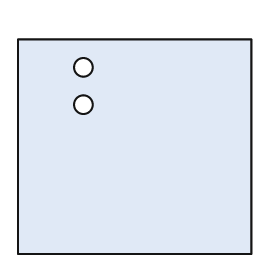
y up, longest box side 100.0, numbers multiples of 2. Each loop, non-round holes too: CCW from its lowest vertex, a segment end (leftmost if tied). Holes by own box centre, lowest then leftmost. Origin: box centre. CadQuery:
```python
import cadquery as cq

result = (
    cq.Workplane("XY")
    .moveTo(-50.0, -46.0)
    .lineTo(50.0, -46.0)
    .lineTo(50.0, 46.0)
    .lineTo(-50.0, 46.0)
    .close()
    .moveTo(-22.0, 18.0)
    .circle(4.0)
    .moveTo(-22.0, 34.0)
    .circle(4.0)
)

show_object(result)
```